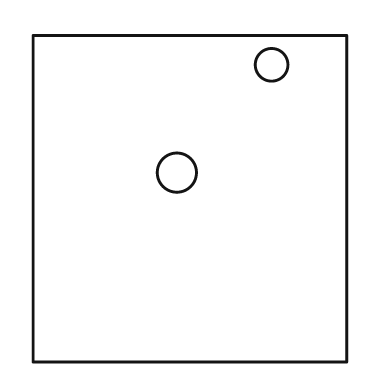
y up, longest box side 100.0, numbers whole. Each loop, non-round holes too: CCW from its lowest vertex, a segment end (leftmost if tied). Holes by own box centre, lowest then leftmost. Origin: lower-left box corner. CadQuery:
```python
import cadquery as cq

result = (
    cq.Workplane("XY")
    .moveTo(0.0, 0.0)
    .lineTo(96.0, 0.0)
    .lineTo(96.0, 100.0)
    .lineTo(0.0, 100.0)
    .close()
    .moveTo(44.0, 58.0)
    .circle(6.0)
    .moveTo(73.0, 91.0)
    .circle(5.0)
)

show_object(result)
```